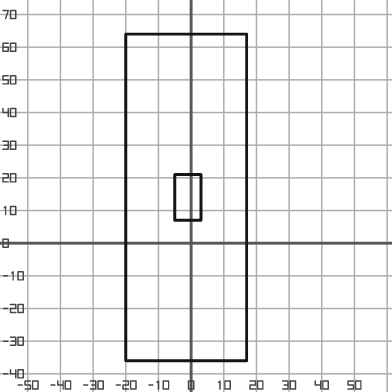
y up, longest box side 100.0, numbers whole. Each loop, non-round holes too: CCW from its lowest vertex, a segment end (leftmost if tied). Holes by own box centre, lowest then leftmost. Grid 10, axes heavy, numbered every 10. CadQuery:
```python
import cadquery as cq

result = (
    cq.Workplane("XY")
    .moveTo(-20.0, -36.0)
    .lineTo(17.0, -36.0)
    .lineTo(17.0, 64.0)
    .lineTo(-20.0, 64.0)
    .close()
    .moveTo(-5.0, 7.0)
    .lineTo(3.0, 7.0)
    .lineTo(3.0, 21.0)
    .lineTo(-5.0, 21.0)
    .close()
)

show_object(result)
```